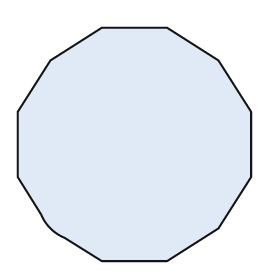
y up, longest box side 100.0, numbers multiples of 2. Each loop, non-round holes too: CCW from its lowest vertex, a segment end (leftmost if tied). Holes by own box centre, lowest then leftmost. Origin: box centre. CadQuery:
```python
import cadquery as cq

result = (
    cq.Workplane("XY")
    .moveTo(-14.0, -50.0)
    .lineTo(14.0, -50.0)
    .lineTo(36.0, -36.0)
    .lineTo(50.0, -14.0)
    .lineTo(50.0, 14.0)
    .lineTo(36.0, 36.0)
    .lineTo(14.0, 50.0)
    .lineTo(-14.0, 50.0)
    .lineTo(-36.0, 36.0)
    .lineTo(-50.0, 14.0)
    .lineTo(-50.0, -14.0)
    .lineTo(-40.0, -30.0)
    .threePointArc((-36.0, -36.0), (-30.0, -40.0))
    .close()
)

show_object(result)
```